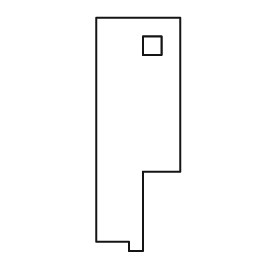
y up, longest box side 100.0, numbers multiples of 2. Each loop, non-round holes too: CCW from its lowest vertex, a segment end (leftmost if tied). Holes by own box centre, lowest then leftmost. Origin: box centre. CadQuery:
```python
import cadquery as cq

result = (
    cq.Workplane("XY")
    .moveTo(-4.0, -50.0)
    .lineTo(2.0, -50.0)
    .lineTo(2.0, -16.0)
    .lineTo(18.0, -16.0)
    .lineTo(18.0, 50.0)
    .lineTo(-18.0, 50.0)
    .lineTo(-18.0, -46.0)
    .lineTo(-4.0, -46.0)
    .close()
    .moveTo(2.0, 34.0)
    .lineTo(10.0, 34.0)
    .lineTo(10.0, 42.0)
    .lineTo(2.0, 42.0)
    .close()
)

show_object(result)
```